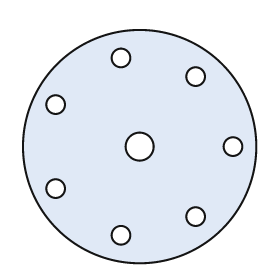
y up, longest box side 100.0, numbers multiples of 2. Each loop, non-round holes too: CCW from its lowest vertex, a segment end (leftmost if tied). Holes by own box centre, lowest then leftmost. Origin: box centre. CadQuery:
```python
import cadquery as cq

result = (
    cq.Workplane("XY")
    .moveTo(0.0, 0.0)
    .circle(50.0)
    .moveTo(-8.0, -38.0)
    .circle(4.0)
    .moveTo(24.0, -30.0)
    .circle(4.0)
    .moveTo(-36.0, -18.0)
    .circle(4.0)
    .moveTo(0.0, 0.0)
    .circle(6.0)
    .moveTo(40.0, 0.0)
    .circle(4.0)
    .moveTo(-36.0, 18.0)
    .circle(4.0)
    .moveTo(24.0, 30.0)
    .circle(4.0)
    .moveTo(-8.0, 38.0)
    .circle(4.0)
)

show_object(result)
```